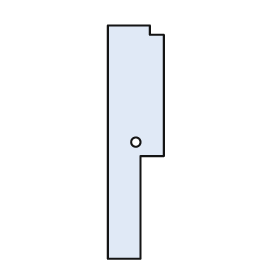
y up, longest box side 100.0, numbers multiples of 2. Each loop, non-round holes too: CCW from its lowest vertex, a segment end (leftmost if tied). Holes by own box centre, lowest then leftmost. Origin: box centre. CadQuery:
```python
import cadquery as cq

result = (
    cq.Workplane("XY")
    .moveTo(-12.0, -50.0)
    .lineTo(2.0, -50.0)
    .lineTo(2.0, -6.0)
    .lineTo(12.0, -6.0)
    .lineTo(12.0, 46.0)
    .lineTo(6.0, 46.0)
    .lineTo(6.0, 50.0)
    .lineTo(-12.0, 50.0)
    .close()
    .moveTo(0.0, 0.0)
    .circle(2.0)
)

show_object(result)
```